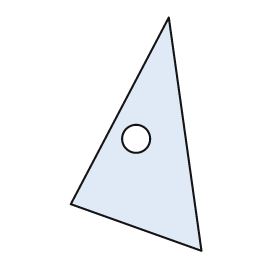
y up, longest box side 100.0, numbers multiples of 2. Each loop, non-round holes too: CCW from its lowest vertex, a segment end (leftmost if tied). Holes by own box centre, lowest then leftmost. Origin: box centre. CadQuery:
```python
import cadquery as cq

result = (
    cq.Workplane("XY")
    .moveTo(28.0, -50.0)
    .lineTo(14.0, 50.0)
    .lineTo(-28.0, -30.0)
    .close()
    .moveTo(0.0, -2.0)
    .circle(6.0)
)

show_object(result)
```